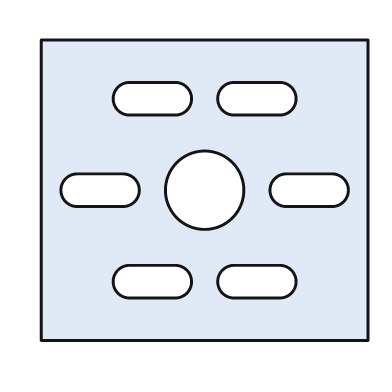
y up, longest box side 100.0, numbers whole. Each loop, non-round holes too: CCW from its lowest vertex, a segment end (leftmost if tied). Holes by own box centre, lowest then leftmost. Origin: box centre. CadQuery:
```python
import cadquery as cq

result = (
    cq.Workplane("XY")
    .moveTo(-50.0, -46.0)
    .lineTo(50.0, -46.0)
    .lineTo(50.0, 46.0)
    .lineTo(-50.0, 46.0)
    .close()
    .moveTo(-23.0, -33.0)
    .lineTo(-9.0, -33.0)
    .threePointArc((-4.0, -28.0), (-9.0, -23.0))
    .lineTo(-23.0, -23.0)
    .threePointArc((-28.0, -28.0), (-23.0, -33.0))
    .close()
    .moveTo(9.0, -33.0)
    .lineTo(23.0, -33.0)
    .threePointArc((28.0, -28.0), (23.0, -23.0))
    .lineTo(9.0, -23.0)
    .threePointArc((4.0, -28.0), (9.0, -33.0))
    .close()
    .moveTo(-39.0, -5.0)
    .lineTo(-25.0, -5.0)
    .threePointArc((-20.0, 0.0), (-25.0, 5.0))
    .lineTo(-39.0, 5.0)
    .threePointArc((-44.0, 0.0), (-39.0, -5.0))
    .close()
    .moveTo(0.0, 0.0)
    .circle(12.0)
    .moveTo(25.0, -5.0)
    .lineTo(39.0, -5.0)
    .threePointArc((44.0, 0.0), (39.0, 5.0))
    .lineTo(25.0, 5.0)
    .threePointArc((20.0, 0.0), (25.0, -5.0))
    .close()
    .moveTo(-23.0, 23.0)
    .lineTo(-9.0, 23.0)
    .threePointArc((-4.0, 28.0), (-9.0, 33.0))
    .lineTo(-23.0, 33.0)
    .threePointArc((-28.0, 28.0), (-23.0, 23.0))
    .close()
    .moveTo(9.0, 23.0)
    .lineTo(23.0, 23.0)
    .threePointArc((28.0, 28.0), (23.0, 33.0))
    .lineTo(9.0, 33.0)
    .threePointArc((4.0, 28.0), (9.0, 23.0))
    .close()
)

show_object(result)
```